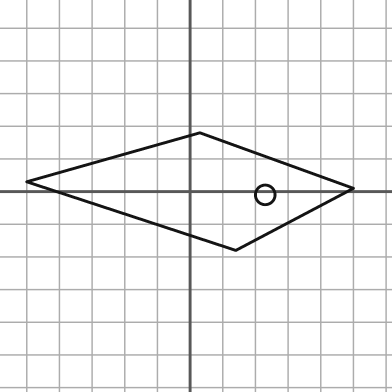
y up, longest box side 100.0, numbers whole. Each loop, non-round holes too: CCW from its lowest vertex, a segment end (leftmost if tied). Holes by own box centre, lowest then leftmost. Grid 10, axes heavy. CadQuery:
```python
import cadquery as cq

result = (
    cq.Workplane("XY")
    .moveTo(14.0, -18.0)
    .lineTo(50.0, 1.0)
    .lineTo(3.0, 18.0)
    .lineTo(-50.0, 3.0)
    .close()
    .moveTo(23.0, -1.0)
    .circle(3.0)
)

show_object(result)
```